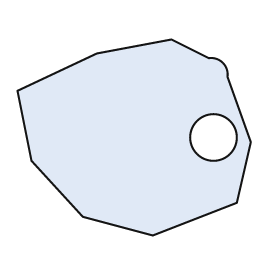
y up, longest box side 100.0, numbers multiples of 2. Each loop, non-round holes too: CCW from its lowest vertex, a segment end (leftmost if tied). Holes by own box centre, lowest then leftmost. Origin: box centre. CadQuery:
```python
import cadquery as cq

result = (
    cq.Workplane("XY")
    .moveTo(8.0, -42.0)
    .lineTo(44.0, -28.0)
    .lineTo(50.0, -2.0)
    .lineTo(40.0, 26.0)
    .threePointArc((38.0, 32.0), (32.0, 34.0))
    .lineTo(16.0, 42.0)
    .lineTo(-16.0, 36.0)
    .lineTo(-50.0, 20.0)
    .lineTo(-44.0, -10.0)
    .lineTo(-22.0, -34.0)
    .close()
    .moveTo(34.0, 0.0)
    .circle(10.0)
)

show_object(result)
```